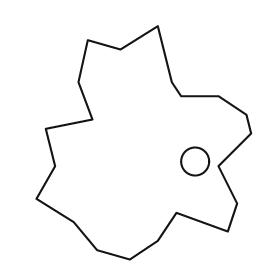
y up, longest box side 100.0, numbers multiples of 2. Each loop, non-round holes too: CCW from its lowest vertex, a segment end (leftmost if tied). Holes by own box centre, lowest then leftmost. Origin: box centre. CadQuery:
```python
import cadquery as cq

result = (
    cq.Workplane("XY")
    .moveTo(-6.0, -50.0)
    .lineTo(6.0, -42.0)
    .lineTo(14.0, -30.0)
    .lineTo(36.0, -38.0)
    .lineTo(40.0, -26.0)
    .lineTo(32.0, -10.0)
    .lineTo(46.0, 4.0)
    .lineTo(44.0, 12.0)
    .lineTo(32.0, 20.0)
    .lineTo(16.0, 20.0)
    .lineTo(12.0, 26.0)
    .lineTo(6.0, 50.0)
    .lineTo(-10.0, 40.0)
    .lineTo(-24.0, 44.0)
    .lineTo(-28.0, 26.0)
    .lineTo(-22.0, 10.0)
    .lineTo(-42.0, 6.0)
    .lineTo(-38.0, -10.0)
    .lineTo(-46.0, -24.0)
    .lineTo(-30.0, -34.0)
    .lineTo(-20.0, -46.0)
    .close()
    .moveTo(22.0, -8.0)
    .circle(6.0)
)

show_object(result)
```